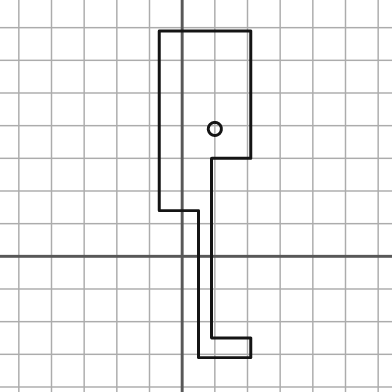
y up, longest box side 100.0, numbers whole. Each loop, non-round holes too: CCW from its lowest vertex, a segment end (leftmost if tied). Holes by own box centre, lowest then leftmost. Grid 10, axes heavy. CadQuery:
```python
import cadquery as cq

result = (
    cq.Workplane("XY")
    .moveTo(5.0, -31.0)
    .lineTo(21.0, -31.0)
    .lineTo(21.0, -25.0)
    .lineTo(9.0, -25.0)
    .lineTo(9.0, 30.0)
    .lineTo(21.0, 30.0)
    .lineTo(21.0, 69.0)
    .lineTo(-7.0, 69.0)
    .lineTo(-7.0, 14.0)
    .lineTo(5.0, 14.0)
    .close()
    .moveTo(10.0, 39.0)
    .circle(2.0)
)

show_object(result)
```